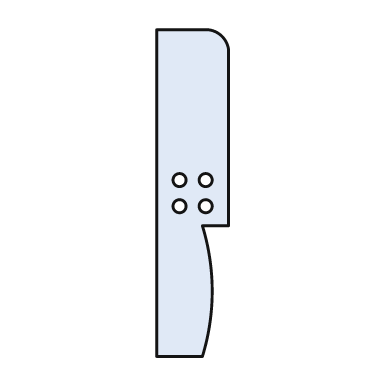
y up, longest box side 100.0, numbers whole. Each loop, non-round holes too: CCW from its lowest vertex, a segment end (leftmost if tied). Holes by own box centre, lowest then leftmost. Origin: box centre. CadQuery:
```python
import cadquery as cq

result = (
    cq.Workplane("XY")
    .moveTo(-11.0, -50.0)
    .lineTo(3.0, -50.0)
    .threePointArc((6.0, -30.0), (3.0, -10.0))
    .lineTo(11.0, -10.0)
    .lineTo(11.0, 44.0)
    .threePointArc((9.0, 48.0), (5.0, 50.0))
    .lineTo(-11.0, 50.0)
    .close()
    .moveTo(-4.0, -4.0)
    .circle(2.0)
    .moveTo(4.0, -4.0)
    .circle(2.0)
    .moveTo(-4.0, 4.0)
    .circle(2.0)
    .moveTo(4.0, 4.0)
    .circle(2.0)
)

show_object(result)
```